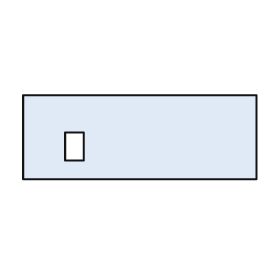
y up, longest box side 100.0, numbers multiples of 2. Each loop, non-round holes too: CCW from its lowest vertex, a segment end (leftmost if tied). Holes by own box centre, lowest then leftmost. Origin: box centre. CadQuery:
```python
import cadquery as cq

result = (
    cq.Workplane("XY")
    .moveTo(-50.0, -18.0)
    .lineTo(50.0, -18.0)
    .lineTo(50.0, 18.0)
    .lineTo(-50.0, 18.0)
    .close()
    .moveTo(-32.0, -10.0)
    .lineTo(-24.0, -10.0)
    .lineTo(-24.0, 2.0)
    .lineTo(-32.0, 2.0)
    .close()
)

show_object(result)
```